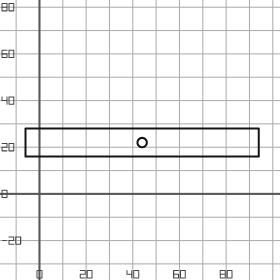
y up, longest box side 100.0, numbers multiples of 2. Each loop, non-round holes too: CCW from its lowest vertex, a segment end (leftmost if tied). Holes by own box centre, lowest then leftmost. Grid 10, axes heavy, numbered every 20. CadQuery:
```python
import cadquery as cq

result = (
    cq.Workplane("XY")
    .moveTo(-6.0, 16.0)
    .lineTo(94.0, 16.0)
    .lineTo(94.0, 28.0)
    .lineTo(-6.0, 28.0)
    .close()
    .moveTo(44.0, 22.0)
    .circle(2.0)
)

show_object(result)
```